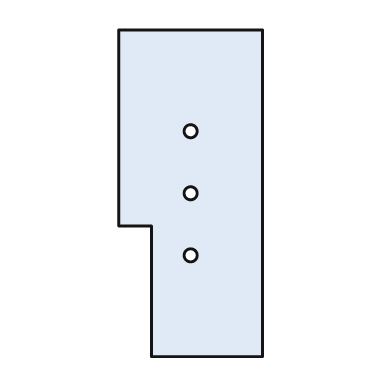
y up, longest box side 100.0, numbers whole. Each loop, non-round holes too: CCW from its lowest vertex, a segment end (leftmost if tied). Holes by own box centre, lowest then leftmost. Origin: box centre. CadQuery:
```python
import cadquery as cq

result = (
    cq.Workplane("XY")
    .moveTo(-12.0, -50.0)
    .lineTo(22.0, -50.0)
    .lineTo(22.0, 50.0)
    .lineTo(-22.0, 50.0)
    .lineTo(-22.0, -10.0)
    .lineTo(-12.0, -10.0)
    .close()
    .moveTo(0.0, -19.0)
    .circle(2.0)
    .moveTo(0.0, 0.0)
    .circle(2.0)
    .moveTo(0.0, 19.0)
    .circle(2.0)
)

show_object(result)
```